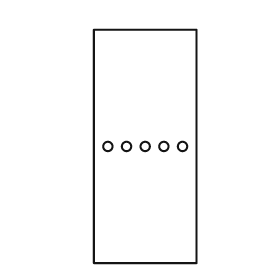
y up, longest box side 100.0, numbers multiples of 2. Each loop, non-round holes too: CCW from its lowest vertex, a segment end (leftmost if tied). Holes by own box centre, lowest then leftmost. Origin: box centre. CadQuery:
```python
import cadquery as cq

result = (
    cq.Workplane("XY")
    .moveTo(-22.0, -50.0)
    .lineTo(22.0, -50.0)
    .lineTo(22.0, 50.0)
    .lineTo(-22.0, 50.0)
    .close()
    .moveTo(-16.0, 0.0)
    .circle(2.0)
    .moveTo(-8.0, 0.0)
    .circle(2.0)
    .moveTo(0.0, 0.0)
    .circle(2.0)
    .moveTo(8.0, 0.0)
    .circle(2.0)
    .moveTo(16.0, 0.0)
    .circle(2.0)
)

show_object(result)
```